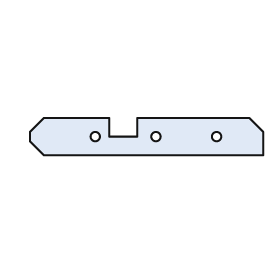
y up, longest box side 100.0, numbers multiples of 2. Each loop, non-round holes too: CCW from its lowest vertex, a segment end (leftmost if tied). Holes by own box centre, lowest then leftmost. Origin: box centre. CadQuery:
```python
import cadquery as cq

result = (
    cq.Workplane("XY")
    .moveTo(-44.0, -8.0)
    .lineTo(50.0, -8.0)
    .lineTo(50.0, 2.0)
    .lineTo(44.0, 8.0)
    .lineTo(-4.0, 8.0)
    .lineTo(-4.0, 0.0)
    .lineTo(-16.0, 0.0)
    .lineTo(-16.0, 8.0)
    .lineTo(-44.0, 8.0)
    .lineTo(-50.0, 2.0)
    .lineTo(-50.0, -2.0)
    .close()
    .moveTo(-22.0, 0.0)
    .circle(2.0)
    .moveTo(4.0, 0.0)
    .circle(2.0)
    .moveTo(30.0, 0.0)
    .circle(2.0)
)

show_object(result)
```